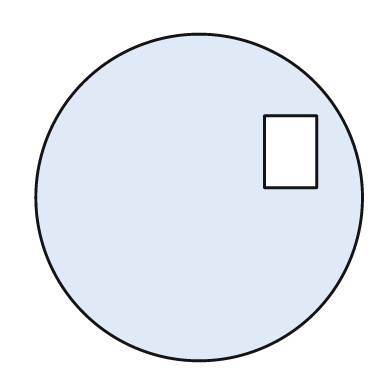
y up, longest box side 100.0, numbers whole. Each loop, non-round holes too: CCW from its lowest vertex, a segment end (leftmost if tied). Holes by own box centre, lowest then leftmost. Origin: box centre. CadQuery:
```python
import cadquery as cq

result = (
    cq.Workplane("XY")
    .moveTo(0.0, 0.0)
    .circle(50.0)
    .moveTo(20.0, 3.0)
    .lineTo(36.0, 3.0)
    .lineTo(36.0, 25.0)
    .lineTo(20.0, 25.0)
    .close()
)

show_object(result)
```